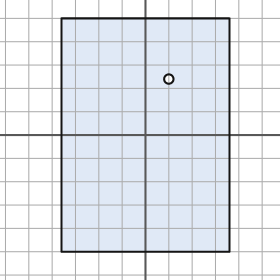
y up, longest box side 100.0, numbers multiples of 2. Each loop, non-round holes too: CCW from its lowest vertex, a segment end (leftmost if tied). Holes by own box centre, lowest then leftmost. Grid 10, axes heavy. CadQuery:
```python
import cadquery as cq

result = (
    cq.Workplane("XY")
    .moveTo(-36.0, -50.0)
    .lineTo(36.0, -50.0)
    .lineTo(36.0, 50.0)
    .lineTo(-36.0, 50.0)
    .close()
    .moveTo(10.0, 24.0)
    .circle(2.0)
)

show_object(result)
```